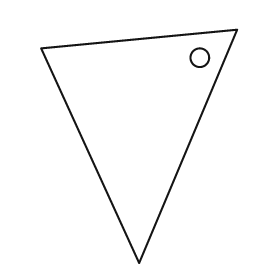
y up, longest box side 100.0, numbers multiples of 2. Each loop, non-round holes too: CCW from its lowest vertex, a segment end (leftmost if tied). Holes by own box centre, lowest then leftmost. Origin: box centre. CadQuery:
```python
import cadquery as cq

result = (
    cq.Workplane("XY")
    .moveTo(0.0, -50.0)
    .lineTo(42.0, 50.0)
    .lineTo(-42.0, 42.0)
    .close()
    .moveTo(26.0, 38.0)
    .circle(4.0)
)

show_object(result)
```